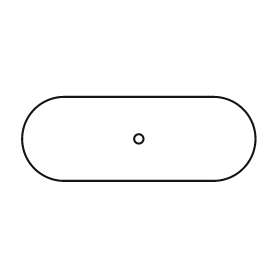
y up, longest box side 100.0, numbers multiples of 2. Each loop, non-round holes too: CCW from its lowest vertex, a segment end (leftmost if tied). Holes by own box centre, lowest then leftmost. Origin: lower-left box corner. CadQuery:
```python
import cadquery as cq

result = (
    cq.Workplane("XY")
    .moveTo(18.0, 0.0)
    .lineTo(82.0, 0.0)
    .threePointArc((100.0, 18.0), (82.0, 36.0))
    .lineTo(18.0, 36.0)
    .threePointArc((0.0, 18.0), (18.0, 0.0))
    .close()
    .moveTo(50.0, 18.0)
    .circle(2.0)
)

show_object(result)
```